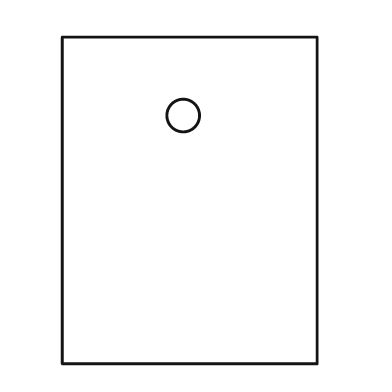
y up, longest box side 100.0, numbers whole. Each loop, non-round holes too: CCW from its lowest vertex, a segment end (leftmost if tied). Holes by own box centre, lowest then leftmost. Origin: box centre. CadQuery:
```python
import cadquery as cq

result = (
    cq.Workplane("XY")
    .moveTo(-39.0, -50.0)
    .lineTo(39.0, -50.0)
    .lineTo(39.0, 50.0)
    .lineTo(-39.0, 50.0)
    .close()
    .moveTo(-2.0, 26.0)
    .circle(5.0)
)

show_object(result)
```